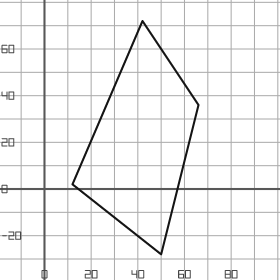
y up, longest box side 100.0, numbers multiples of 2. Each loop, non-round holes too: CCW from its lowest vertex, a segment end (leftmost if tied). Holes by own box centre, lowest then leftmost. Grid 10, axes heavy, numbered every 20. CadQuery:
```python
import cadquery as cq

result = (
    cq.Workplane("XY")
    .moveTo(50.0, -28.0)
    .lineTo(66.0, 36.0)
    .lineTo(42.0, 72.0)
    .lineTo(12.0, 2.0)
    .close()
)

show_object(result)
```